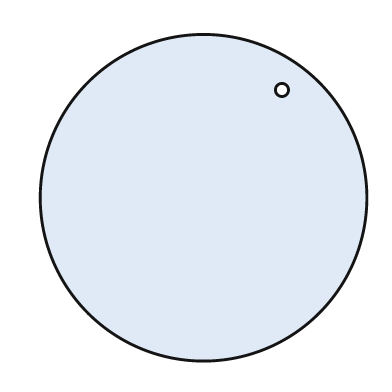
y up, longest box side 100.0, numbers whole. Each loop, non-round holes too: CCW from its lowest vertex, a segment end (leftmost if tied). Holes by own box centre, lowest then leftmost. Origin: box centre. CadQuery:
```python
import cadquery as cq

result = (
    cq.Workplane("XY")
    .moveTo(0.0, 0.0)
    .circle(50.0)
    .moveTo(24.0, 33.0)
    .circle(2.0)
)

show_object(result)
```